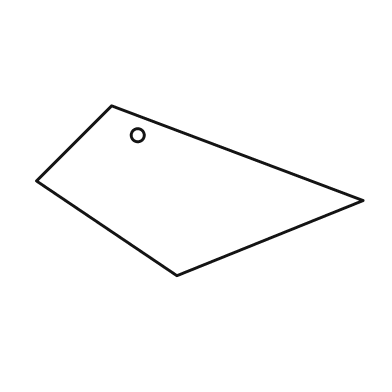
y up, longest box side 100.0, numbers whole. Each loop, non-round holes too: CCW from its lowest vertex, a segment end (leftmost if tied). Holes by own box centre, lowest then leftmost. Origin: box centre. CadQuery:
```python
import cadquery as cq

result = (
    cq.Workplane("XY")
    .moveTo(-7.0, -26.0)
    .lineTo(50.0, -3.0)
    .lineTo(-27.0, 26.0)
    .lineTo(-50.0, 3.0)
    .close()
    .moveTo(-19.0, 17.0)
    .circle(2.0)
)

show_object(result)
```